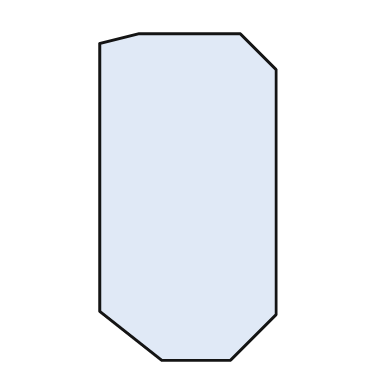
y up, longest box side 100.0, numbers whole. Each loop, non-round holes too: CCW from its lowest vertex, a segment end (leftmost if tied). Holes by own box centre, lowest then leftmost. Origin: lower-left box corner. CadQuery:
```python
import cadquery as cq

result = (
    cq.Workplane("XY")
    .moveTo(19.0, 0.0)
    .lineTo(40.0, 0.0)
    .lineTo(54.0, 14.0)
    .lineTo(54.0, 89.0)
    .lineTo(43.0, 100.0)
    .lineTo(12.0, 100.0)
    .lineTo(0.0, 97.0)
    .lineTo(0.0, 15.0)
    .close()
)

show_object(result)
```